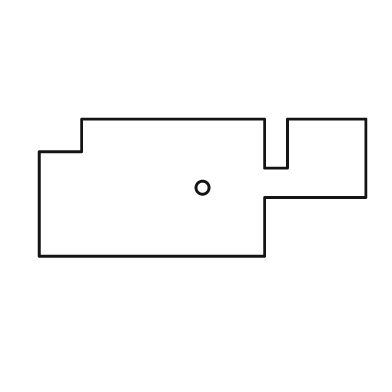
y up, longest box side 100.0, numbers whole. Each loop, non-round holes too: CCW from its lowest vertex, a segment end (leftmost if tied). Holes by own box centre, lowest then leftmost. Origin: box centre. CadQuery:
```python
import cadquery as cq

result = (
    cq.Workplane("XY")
    .moveTo(-50.0, -21.0)
    .lineTo(19.0, -21.0)
    .lineTo(19.0, -3.0)
    .lineTo(50.0, -3.0)
    .lineTo(50.0, 21.0)
    .lineTo(26.0, 21.0)
    .lineTo(26.0, 6.0)
    .lineTo(19.0, 6.0)
    .lineTo(19.0, 21.0)
    .lineTo(-37.0, 21.0)
    .lineTo(-37.0, 11.0)
    .lineTo(-50.0, 11.0)
    .close()
    .moveTo(0.0, 0.0)
    .circle(2.0)
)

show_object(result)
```